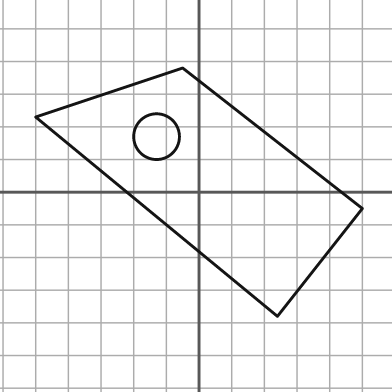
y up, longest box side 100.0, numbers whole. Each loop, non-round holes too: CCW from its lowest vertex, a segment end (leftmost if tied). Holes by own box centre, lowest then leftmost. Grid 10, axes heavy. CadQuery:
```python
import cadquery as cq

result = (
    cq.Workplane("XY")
    .moveTo(24.0, -38.0)
    .lineTo(50.0, -5.0)
    .lineTo(-5.0, 38.0)
    .lineTo(-50.0, 23.0)
    .close()
    .moveTo(-13.0, 17.0)
    .circle(7.0)
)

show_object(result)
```